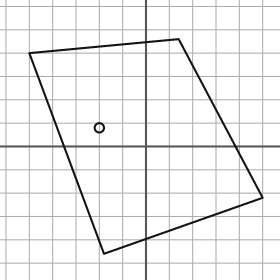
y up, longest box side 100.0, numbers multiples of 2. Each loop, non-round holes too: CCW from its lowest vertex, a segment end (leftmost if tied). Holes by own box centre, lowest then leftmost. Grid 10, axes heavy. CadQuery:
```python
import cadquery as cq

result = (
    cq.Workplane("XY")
    .moveTo(-18.0, -46.0)
    .lineTo(50.0, -22.0)
    .lineTo(14.0, 46.0)
    .lineTo(-50.0, 40.0)
    .close()
    .moveTo(-20.0, 8.0)
    .circle(2.0)
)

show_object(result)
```